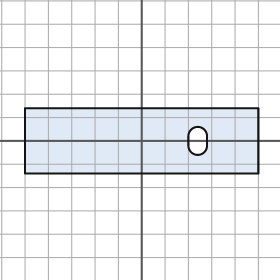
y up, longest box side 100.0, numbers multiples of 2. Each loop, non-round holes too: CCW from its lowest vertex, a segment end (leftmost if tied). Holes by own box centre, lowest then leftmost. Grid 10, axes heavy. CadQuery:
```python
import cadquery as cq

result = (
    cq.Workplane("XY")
    .moveTo(-50.0, -14.0)
    .lineTo(50.0, -14.0)
    .lineTo(50.0, 14.0)
    .lineTo(-50.0, 14.0)
    .close()
    .moveTo(20.0, -2.0)
    .threePointArc((24.0, -6.0), (28.0, -2.0))
    .lineTo(28.0, 2.0)
    .threePointArc((24.0, 6.0), (20.0, 2.0))
    .close()
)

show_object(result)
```